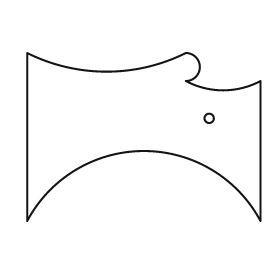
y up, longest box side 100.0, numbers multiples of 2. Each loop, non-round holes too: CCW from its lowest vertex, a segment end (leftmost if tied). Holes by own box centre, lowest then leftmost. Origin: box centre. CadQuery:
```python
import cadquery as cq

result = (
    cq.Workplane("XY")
    .moveTo(-50.0, -36.0)
    .threePointArc((0.0, -6.0), (50.0, -36.0))
    .lineTo(50.0, 24.0)
    .threePointArc((34.0, 20.0), (18.0, 24.0))
    .threePointArc((24.0, 30.0), (18.0, 36.0))
    .threePointArc((-16.0, 28.0), (-50.0, 36.0))
    .close()
    .moveTo(28.0, 8.0)
    .circle(2.0)
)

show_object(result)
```